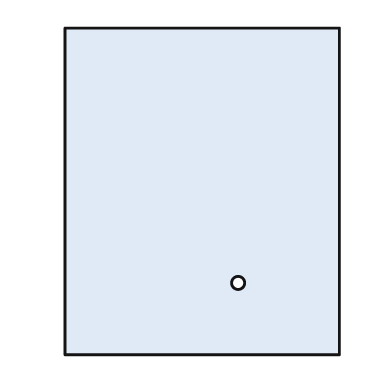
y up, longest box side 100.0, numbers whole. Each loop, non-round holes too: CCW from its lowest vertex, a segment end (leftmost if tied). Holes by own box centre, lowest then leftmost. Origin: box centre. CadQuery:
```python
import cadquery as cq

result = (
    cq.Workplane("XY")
    .moveTo(-42.0, -50.0)
    .lineTo(42.0, -50.0)
    .lineTo(42.0, 50.0)
    .lineTo(-42.0, 50.0)
    .close()
    .moveTo(11.0, -28.0)
    .circle(2.0)
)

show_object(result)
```